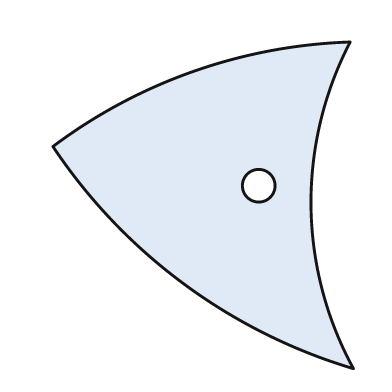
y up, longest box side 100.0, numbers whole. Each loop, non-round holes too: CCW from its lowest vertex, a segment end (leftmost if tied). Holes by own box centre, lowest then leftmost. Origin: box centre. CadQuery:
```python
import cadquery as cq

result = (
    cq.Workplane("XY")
    .moveTo(46.0, -50.0)
    .threePointArc((33.0, 0.0), (45.0, 50.0))
    .threePointArc((-3.0, 41.0), (-46.0, 18.0))
    .threePointArc((-6.0, -24.0), (46.0, -50.0))
    .close()
    .moveTo(17.0, 6.0)
    .circle(5.0)
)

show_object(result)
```